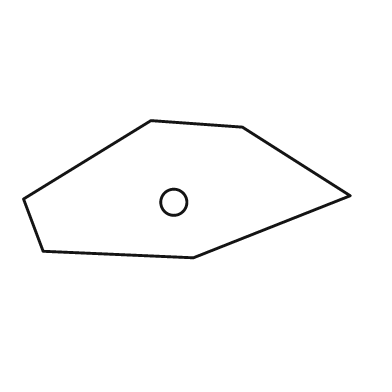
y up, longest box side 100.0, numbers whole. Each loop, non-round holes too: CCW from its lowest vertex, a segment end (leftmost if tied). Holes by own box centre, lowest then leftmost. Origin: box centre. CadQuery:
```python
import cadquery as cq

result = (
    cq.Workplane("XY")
    .moveTo(2.0, -21.0)
    .lineTo(50.0, -2.0)
    .lineTo(17.0, 19.0)
    .lineTo(-11.0, 21.0)
    .lineTo(-50.0, -3.0)
    .lineTo(-44.0, -19.0)
    .close()
    .moveTo(-4.0, -4.0)
    .circle(4.0)
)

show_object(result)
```